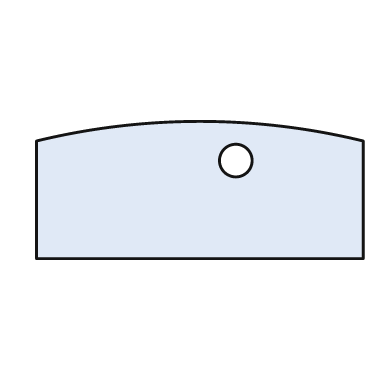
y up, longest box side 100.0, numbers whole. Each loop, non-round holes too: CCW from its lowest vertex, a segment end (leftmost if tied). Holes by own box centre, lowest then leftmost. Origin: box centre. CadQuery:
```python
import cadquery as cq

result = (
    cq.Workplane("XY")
    .moveTo(-50.0, -21.0)
    .lineTo(50.0, -21.0)
    .lineTo(50.0, 15.0)
    .threePointArc((0.0, 21.0), (-50.0, 15.0))
    .close()
    .moveTo(11.0, 9.0)
    .circle(5.0)
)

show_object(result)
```